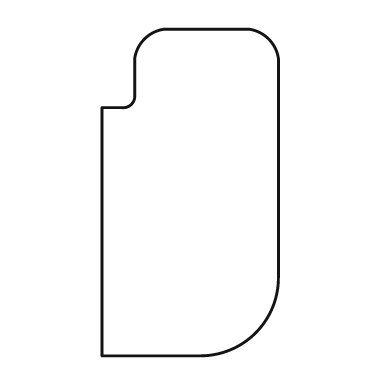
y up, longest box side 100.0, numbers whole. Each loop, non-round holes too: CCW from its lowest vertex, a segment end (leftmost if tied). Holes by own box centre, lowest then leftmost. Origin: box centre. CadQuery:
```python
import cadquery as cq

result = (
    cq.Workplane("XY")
    .moveTo(-27.0, -50.0)
    .lineTo(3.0, -50.0)
    .threePointArc((20.0, -43.0), (27.0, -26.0))
    .lineTo(27.0, 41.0)
    .threePointArc((24.0, 47.0), (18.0, 50.0))
    .lineTo(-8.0, 50.0)
    .threePointArc((-14.0, 47.0), (-17.0, 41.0))
    .lineTo(-17.0, 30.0)
    .threePointArc((-18.0, 27.0), (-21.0, 26.0))
    .lineTo(-27.0, 26.0)
    .close()
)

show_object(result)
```